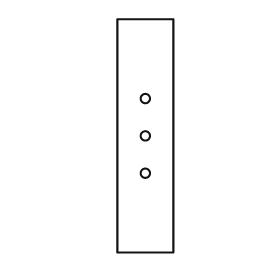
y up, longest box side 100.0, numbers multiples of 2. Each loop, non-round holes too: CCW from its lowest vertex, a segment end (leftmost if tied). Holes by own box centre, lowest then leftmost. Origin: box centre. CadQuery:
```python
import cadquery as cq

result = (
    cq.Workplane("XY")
    .moveTo(-12.0, -50.0)
    .lineTo(12.0, -50.0)
    .lineTo(12.0, 50.0)
    .lineTo(-12.0, 50.0)
    .close()
    .moveTo(0.0, -16.0)
    .circle(2.0)
    .moveTo(0.0, 0.0)
    .circle(2.0)
    .moveTo(0.0, 16.0)
    .circle(2.0)
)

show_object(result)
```